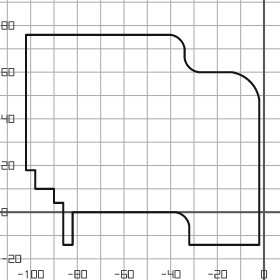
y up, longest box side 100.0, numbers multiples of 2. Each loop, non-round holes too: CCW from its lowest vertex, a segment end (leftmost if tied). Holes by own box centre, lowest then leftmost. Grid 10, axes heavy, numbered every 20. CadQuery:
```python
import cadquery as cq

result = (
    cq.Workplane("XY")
    .moveTo(-86.0, -14.0)
    .lineTo(-82.0, -14.0)
    .lineTo(-82.0, 0.0)
    .lineTo(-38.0, 0.0)
    .threePointArc((-34.0, -2.0), (-32.0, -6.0))
    .lineTo(-32.0, -14.0)
    .lineTo(-2.0, -14.0)
    .lineTo(-2.0, 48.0)
    .threePointArc((-6.0, 56.0), (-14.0, 60.0))
    .lineTo(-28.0, 60.0)
    .threePointArc((-32.0, 62.0), (-34.0, 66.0))
    .lineTo(-34.0, 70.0)
    .threePointArc((-36.0, 74.0), (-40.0, 76.0))
    .lineTo(-102.0, 76.0)
    .lineTo(-102.0, 18.0)
    .lineTo(-98.0, 18.0)
    .lineTo(-98.0, 10.0)
    .lineTo(-90.0, 10.0)
    .lineTo(-90.0, 4.0)
    .lineTo(-86.0, 4.0)
    .close()
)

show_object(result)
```